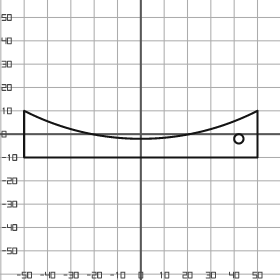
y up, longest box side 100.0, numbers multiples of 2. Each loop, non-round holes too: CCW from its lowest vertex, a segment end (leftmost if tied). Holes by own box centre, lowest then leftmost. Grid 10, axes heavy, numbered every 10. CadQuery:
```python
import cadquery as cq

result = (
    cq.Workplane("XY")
    .moveTo(-50.0, -10.0)
    .lineTo(50.0, -10.0)
    .lineTo(50.0, 10.0)
    .threePointArc((0.0, -2.0), (-50.0, 10.0))
    .close()
    .moveTo(42.0, -2.0)
    .circle(2.0)
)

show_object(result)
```